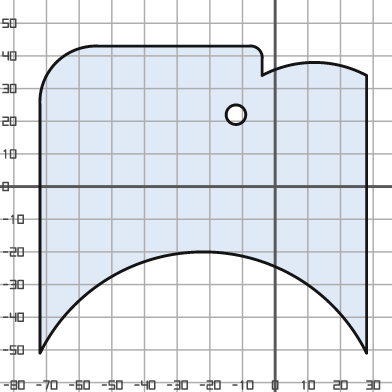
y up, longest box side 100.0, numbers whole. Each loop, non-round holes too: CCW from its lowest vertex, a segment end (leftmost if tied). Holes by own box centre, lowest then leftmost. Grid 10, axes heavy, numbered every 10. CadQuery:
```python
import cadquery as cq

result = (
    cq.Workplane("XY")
    .moveTo(-72.0, -51.0)
    .threePointArc((-22.0, -20.0), (28.0, -51.0))
    .lineTo(28.0, 34.0)
    .threePointArc((12.0, 38.0), (-4.0, 34.0))
    .lineTo(-4.0, 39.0)
    .threePointArc((-5.0, 42.0), (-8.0, 43.0))
    .lineTo(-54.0, 43.0)
    .threePointArc((-67.0, 38.0), (-72.0, 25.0))
    .close()
    .moveTo(-12.0, 22.0)
    .circle(3.0)
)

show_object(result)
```